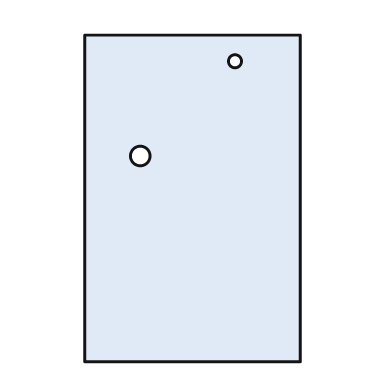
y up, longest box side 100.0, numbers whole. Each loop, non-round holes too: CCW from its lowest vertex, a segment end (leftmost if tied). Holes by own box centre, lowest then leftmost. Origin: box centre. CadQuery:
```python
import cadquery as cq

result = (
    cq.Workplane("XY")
    .moveTo(-33.0, -50.0)
    .lineTo(33.0, -50.0)
    .lineTo(33.0, 50.0)
    .lineTo(-33.0, 50.0)
    .close()
    .moveTo(-16.0, 13.0)
    .circle(3.0)
    .moveTo(13.0, 42.0)
    .circle(2.0)
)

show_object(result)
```